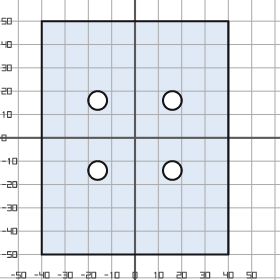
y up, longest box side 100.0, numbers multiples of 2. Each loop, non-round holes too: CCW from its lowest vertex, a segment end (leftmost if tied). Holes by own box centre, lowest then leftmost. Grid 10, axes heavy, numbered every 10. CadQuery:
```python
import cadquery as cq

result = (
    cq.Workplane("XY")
    .moveTo(-40.0, -50.0)
    .lineTo(40.0, -50.0)
    .lineTo(40.0, 50.0)
    .lineTo(-40.0, 50.0)
    .close()
    .moveTo(-16.0, -14.0)
    .circle(4.0)
    .moveTo(16.0, -14.0)
    .circle(4.0)
    .moveTo(-16.0, 16.0)
    .circle(4.0)
    .moveTo(16.0, 16.0)
    .circle(4.0)
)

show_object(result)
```